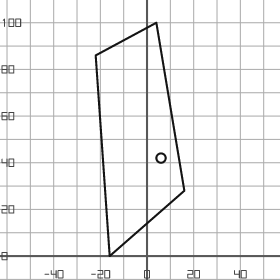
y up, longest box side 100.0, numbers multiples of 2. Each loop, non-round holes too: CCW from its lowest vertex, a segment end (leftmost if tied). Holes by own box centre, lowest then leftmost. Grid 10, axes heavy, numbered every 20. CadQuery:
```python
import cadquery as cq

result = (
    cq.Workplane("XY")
    .moveTo(-16.0, 0.0)
    .lineTo(16.0, 28.0)
    .lineTo(4.0, 100.0)
    .lineTo(-22.0, 86.0)
    .close()
    .moveTo(6.0, 42.0)
    .circle(2.0)
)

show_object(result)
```